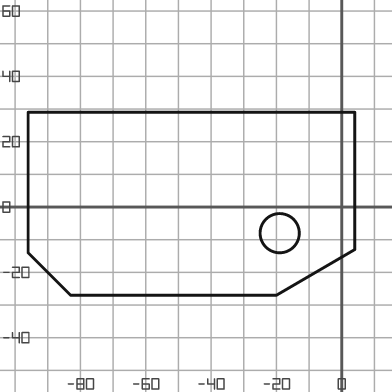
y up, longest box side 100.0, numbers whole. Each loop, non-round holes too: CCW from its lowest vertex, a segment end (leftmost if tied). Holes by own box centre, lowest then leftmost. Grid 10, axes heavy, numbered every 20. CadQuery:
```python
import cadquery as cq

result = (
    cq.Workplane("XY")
    .moveTo(-83.0, -27.0)
    .lineTo(-20.0, -27.0)
    .lineTo(4.0, -13.0)
    .lineTo(4.0, 29.0)
    .lineTo(-96.0, 29.0)
    .lineTo(-96.0, -14.0)
    .close()
    .moveTo(-19.0, -8.0)
    .circle(6.0)
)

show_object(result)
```